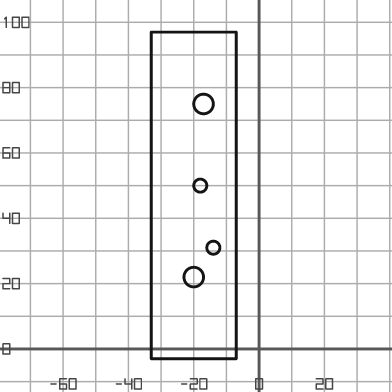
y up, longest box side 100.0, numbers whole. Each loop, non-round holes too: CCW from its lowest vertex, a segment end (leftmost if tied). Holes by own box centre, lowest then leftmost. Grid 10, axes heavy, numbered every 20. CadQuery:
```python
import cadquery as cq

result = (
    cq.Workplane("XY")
    .moveTo(-33.0, -3.0)
    .lineTo(-7.0, -3.0)
    .lineTo(-7.0, 97.0)
    .lineTo(-33.0, 97.0)
    .close()
    .moveTo(-20.0, 22.0)
    .circle(3.0)
    .moveTo(-14.0, 31.0)
    .circle(2.0)
    .moveTo(-18.0, 50.0)
    .circle(2.0)
    .moveTo(-17.0, 75.0)
    .circle(3.0)
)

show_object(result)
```